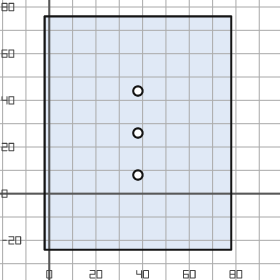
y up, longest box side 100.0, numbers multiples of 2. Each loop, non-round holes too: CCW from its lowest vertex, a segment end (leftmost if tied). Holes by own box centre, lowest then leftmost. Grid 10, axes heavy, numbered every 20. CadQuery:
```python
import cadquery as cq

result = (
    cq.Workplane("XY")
    .moveTo(-2.0, -24.0)
    .lineTo(78.0, -24.0)
    .lineTo(78.0, 76.0)
    .lineTo(-2.0, 76.0)
    .close()
    .moveTo(38.0, 8.0)
    .circle(2.0)
    .moveTo(38.0, 26.0)
    .circle(2.0)
    .moveTo(38.0, 44.0)
    .circle(2.0)
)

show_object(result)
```